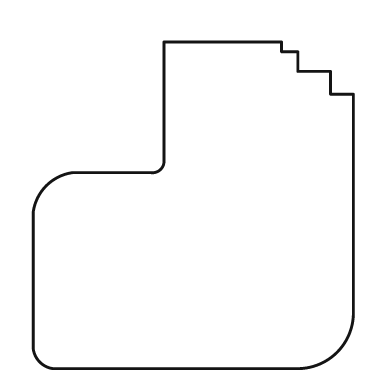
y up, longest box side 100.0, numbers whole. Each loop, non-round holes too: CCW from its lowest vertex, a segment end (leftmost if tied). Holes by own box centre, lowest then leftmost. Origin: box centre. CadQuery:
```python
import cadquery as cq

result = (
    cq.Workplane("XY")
    .moveTo(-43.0, -50.0)
    .lineTo(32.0, -50.0)
    .threePointArc((44.0, -45.0), (49.0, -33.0))
    .lineTo(49.0, 34.0)
    .lineTo(42.0, 34.0)
    .lineTo(42.0, 41.0)
    .lineTo(32.0, 41.0)
    .lineTo(32.0, 47.0)
    .lineTo(27.0, 47.0)
    .lineTo(27.0, 50.0)
    .lineTo(-9.0, 50.0)
    .lineTo(-9.0, 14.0)
    .threePointArc((-10.0, 11.0), (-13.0, 10.0))
    .lineTo(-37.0, 10.0)
    .threePointArc((-45.0, 6.0), (-49.0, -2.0))
    .lineTo(-49.0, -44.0)
    .threePointArc((-47.0, -48.0), (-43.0, -50.0))
    .close()
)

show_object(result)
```